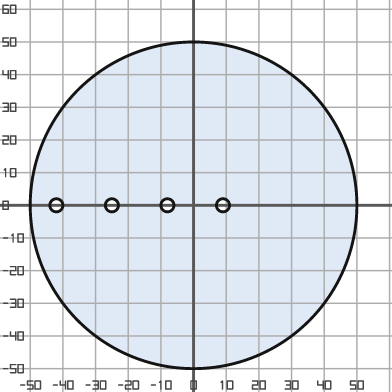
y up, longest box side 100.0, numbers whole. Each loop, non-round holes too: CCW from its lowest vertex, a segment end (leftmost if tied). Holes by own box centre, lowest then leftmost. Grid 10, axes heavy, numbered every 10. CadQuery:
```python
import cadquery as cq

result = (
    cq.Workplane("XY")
    .moveTo(0.0, 0.0)
    .circle(50.0)
    .moveTo(-42.0, 0.0)
    .circle(2.0)
    .moveTo(-25.0, 0.0)
    .circle(2.0)
    .moveTo(-8.0, 0.0)
    .circle(2.0)
    .moveTo(9.0, 0.0)
    .circle(2.0)
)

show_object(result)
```